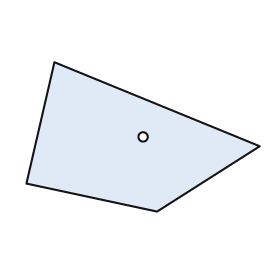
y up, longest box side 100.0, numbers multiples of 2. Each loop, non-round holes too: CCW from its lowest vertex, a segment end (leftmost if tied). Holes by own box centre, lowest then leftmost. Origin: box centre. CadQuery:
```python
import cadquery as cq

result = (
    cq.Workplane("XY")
    .moveTo(6.0, -32.0)
    .lineTo(50.0, -4.0)
    .lineTo(-38.0, 32.0)
    .lineTo(-50.0, -20.0)
    .close()
    .moveTo(0.0, 0.0)
    .circle(2.0)
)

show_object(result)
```